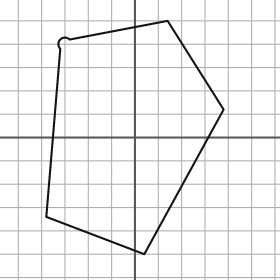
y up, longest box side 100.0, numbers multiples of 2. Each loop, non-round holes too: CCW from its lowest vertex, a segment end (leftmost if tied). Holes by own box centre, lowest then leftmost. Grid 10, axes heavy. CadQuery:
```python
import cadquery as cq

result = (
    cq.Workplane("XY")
    .moveTo(4.0, -50.0)
    .lineTo(38.0, 12.0)
    .lineTo(14.0, 50.0)
    .lineTo(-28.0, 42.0)
    .threePointArc((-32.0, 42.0), (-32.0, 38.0))
    .lineTo(-38.0, -34.0)
    .close()
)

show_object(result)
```